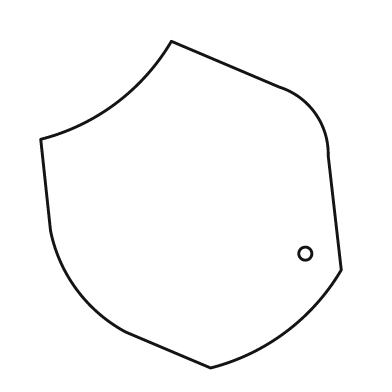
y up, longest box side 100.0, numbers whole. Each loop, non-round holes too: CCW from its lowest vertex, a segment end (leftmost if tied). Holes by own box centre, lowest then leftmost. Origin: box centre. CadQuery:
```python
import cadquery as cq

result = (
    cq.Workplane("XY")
    .moveTo(6.0, -50.0)
    .threePointArc((29.0, -39.0), (46.0, -20.0))
    .lineTo(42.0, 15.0)
    .threePointArc((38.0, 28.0), (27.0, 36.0))
    .lineTo(-6.0, 50.0)
    .threePointArc((-23.0, 31.0), (-46.0, 20.0))
    .lineTo(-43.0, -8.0)
    .threePointArc((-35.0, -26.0), (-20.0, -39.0))
    .close()
    .moveTo(35.0, -15.0)
    .circle(2.0)
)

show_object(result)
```